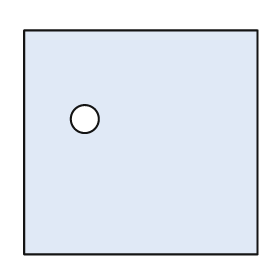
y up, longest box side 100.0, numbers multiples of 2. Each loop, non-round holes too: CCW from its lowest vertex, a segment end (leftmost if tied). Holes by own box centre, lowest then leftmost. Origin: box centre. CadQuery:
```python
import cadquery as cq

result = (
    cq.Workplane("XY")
    .moveTo(-50.0, -48.0)
    .lineTo(50.0, -48.0)
    .lineTo(50.0, 48.0)
    .lineTo(-50.0, 48.0)
    .close()
    .moveTo(-24.0, 10.0)
    .circle(6.0)
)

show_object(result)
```